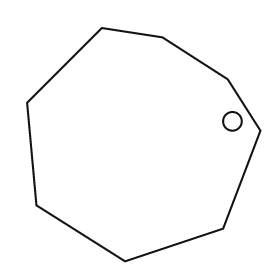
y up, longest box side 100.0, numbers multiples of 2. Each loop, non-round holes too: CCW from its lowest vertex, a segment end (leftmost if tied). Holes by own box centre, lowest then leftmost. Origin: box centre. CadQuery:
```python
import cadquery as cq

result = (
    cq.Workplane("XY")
    .moveTo(-8.0, -50.0)
    .lineTo(34.0, -36.0)
    .lineTo(50.0, 6.0)
    .lineTo(36.0, 28.0)
    .lineTo(8.0, 46.0)
    .lineTo(-18.0, 50.0)
    .lineTo(-50.0, 18.0)
    .lineTo(-46.0, -26.0)
    .close()
    .moveTo(38.0, 10.0)
    .circle(4.0)
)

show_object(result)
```